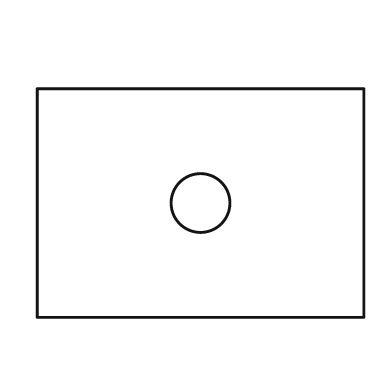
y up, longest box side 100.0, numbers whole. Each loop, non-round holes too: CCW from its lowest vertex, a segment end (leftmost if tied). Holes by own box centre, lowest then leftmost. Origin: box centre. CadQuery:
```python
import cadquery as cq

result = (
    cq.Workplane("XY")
    .moveTo(-50.0, -35.0)
    .lineTo(50.0, -35.0)
    .lineTo(50.0, 35.0)
    .lineTo(-50.0, 35.0)
    .close()
    .moveTo(0.0, 0.0)
    .circle(9.0)
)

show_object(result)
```